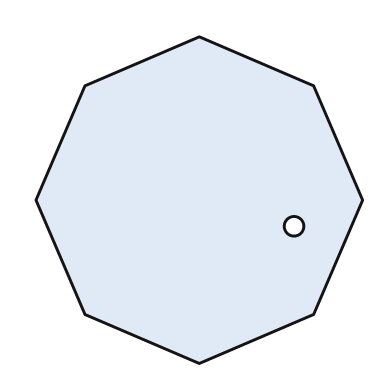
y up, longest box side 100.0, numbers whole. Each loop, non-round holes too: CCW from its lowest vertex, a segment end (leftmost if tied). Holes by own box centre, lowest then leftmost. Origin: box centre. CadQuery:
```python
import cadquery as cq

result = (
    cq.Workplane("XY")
    .moveTo(0.0, -50.0)
    .lineTo(35.0, -35.0)
    .lineTo(50.0, 0.0)
    .lineTo(35.0, 35.0)
    .lineTo(0.0, 50.0)
    .lineTo(-35.0, 35.0)
    .lineTo(-50.0, 0.0)
    .lineTo(-35.0, -35.0)
    .close()
    .moveTo(29.0, -8.0)
    .circle(3.0)
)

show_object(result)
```